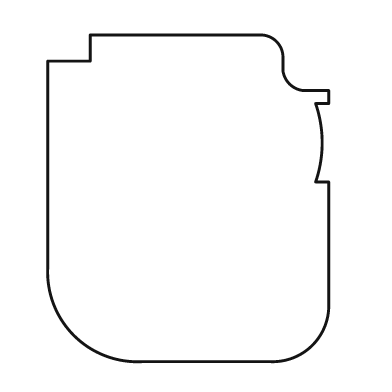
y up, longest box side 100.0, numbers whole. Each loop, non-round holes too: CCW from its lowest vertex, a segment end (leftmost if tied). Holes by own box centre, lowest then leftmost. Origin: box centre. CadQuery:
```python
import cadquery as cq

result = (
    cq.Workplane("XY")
    .moveTo(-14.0, -50.0)
    .lineTo(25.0, -50.0)
    .threePointArc((38.0, -45.0), (43.0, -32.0))
    .lineTo(43.0, 5.0)
    .lineTo(39.0, 5.0)
    .threePointArc((41.0, 17.0), (39.0, 29.0))
    .lineTo(43.0, 29.0)
    .lineTo(43.0, 33.0)
    .lineTo(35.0, 33.0)
    .threePointArc((31.0, 35.0), (29.0, 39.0))
    .lineTo(29.0, 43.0)
    .threePointArc((27.0, 48.0), (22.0, 50.0))
    .lineTo(-30.0, 50.0)
    .lineTo(-30.0, 42.0)
    .lineTo(-43.0, 42.0)
    .lineTo(-43.0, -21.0)
    .threePointArc((-35.0, -42.0), (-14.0, -50.0))
    .close()
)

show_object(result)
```